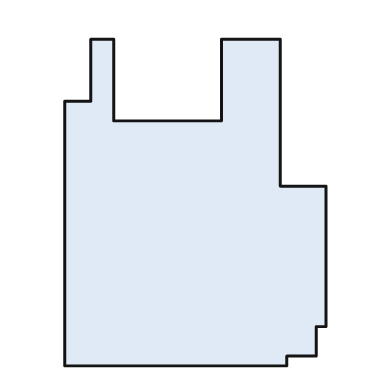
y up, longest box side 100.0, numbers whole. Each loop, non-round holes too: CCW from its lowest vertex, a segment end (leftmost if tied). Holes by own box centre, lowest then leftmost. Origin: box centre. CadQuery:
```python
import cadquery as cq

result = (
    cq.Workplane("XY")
    .moveTo(-40.0, -50.0)
    .lineTo(28.0, -50.0)
    .lineTo(28.0, -47.0)
    .lineTo(37.0, -47.0)
    .lineTo(37.0, -38.0)
    .lineTo(40.0, -38.0)
    .lineTo(40.0, 5.0)
    .lineTo(26.0, 5.0)
    .lineTo(26.0, 50.0)
    .lineTo(8.0, 50.0)
    .lineTo(8.0, 25.0)
    .lineTo(-25.0, 25.0)
    .lineTo(-25.0, 50.0)
    .lineTo(-32.0, 50.0)
    .lineTo(-32.0, 31.0)
    .lineTo(-40.0, 31.0)
    .close()
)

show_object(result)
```